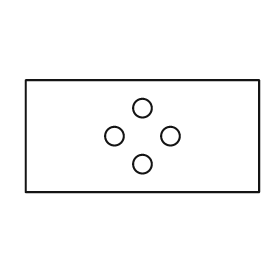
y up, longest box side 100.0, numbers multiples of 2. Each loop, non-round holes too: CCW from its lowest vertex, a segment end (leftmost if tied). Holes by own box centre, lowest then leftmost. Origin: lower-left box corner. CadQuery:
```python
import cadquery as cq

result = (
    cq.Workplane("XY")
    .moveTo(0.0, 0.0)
    .lineTo(100.0, 0.0)
    .lineTo(100.0, 48.0)
    .lineTo(0.0, 48.0)
    .close()
    .moveTo(50.0, 12.0)
    .circle(4.0)
    .moveTo(38.0, 24.0)
    .circle(4.0)
    .moveTo(62.0, 24.0)
    .circle(4.0)
    .moveTo(50.0, 36.0)
    .circle(4.0)
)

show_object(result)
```